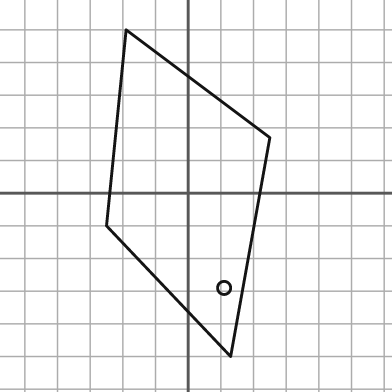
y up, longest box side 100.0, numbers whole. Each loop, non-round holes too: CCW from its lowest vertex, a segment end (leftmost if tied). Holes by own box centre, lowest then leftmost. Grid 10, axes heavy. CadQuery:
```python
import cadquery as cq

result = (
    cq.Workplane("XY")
    .moveTo(13.0, -50.0)
    .lineTo(25.0, 17.0)
    .lineTo(-19.0, 50.0)
    .lineTo(-25.0, -10.0)
    .close()
    .moveTo(11.0, -29.0)
    .circle(2.0)
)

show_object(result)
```